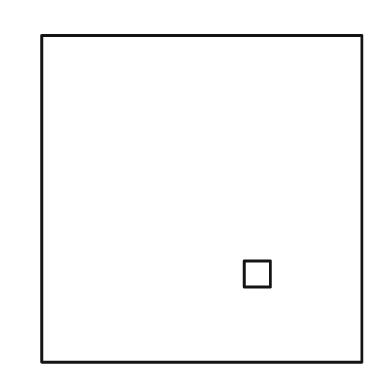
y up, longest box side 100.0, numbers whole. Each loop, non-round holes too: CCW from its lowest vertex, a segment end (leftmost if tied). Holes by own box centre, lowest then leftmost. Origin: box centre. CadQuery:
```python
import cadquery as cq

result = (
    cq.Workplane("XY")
    .moveTo(-49.0, -50.0)
    .lineTo(49.0, -50.0)
    .lineTo(49.0, 50.0)
    .lineTo(-49.0, 50.0)
    .close()
    .moveTo(13.0, -27.0)
    .lineTo(21.0, -27.0)
    .lineTo(21.0, -19.0)
    .lineTo(13.0, -19.0)
    .close()
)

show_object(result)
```